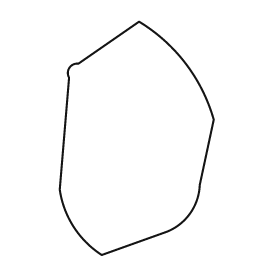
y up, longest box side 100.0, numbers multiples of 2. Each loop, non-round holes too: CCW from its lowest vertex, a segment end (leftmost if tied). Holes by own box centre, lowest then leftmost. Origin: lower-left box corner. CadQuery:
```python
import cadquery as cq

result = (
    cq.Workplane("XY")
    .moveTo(18.0, 0.0)
    .lineTo(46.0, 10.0)
    .threePointArc((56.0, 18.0), (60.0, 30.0))
    .lineTo(66.0, 58.0)
    .threePointArc((54.0, 82.0), (34.0, 100.0))
    .lineTo(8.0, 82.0)
    .threePointArc((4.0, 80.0), (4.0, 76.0))
    .lineTo(0.0, 28.0)
    .threePointArc((6.0, 12.0), (18.0, 0.0))
    .close()
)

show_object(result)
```